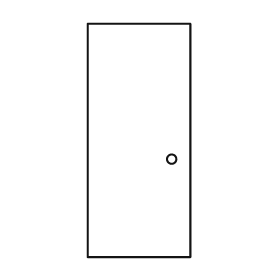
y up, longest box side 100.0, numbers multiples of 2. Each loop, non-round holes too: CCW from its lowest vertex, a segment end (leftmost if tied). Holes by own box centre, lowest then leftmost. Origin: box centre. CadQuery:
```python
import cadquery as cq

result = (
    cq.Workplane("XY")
    .moveTo(-22.0, -50.0)
    .lineTo(22.0, -50.0)
    .lineTo(22.0, 50.0)
    .lineTo(-22.0, 50.0)
    .close()
    .moveTo(14.0, -8.0)
    .circle(2.0)
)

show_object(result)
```